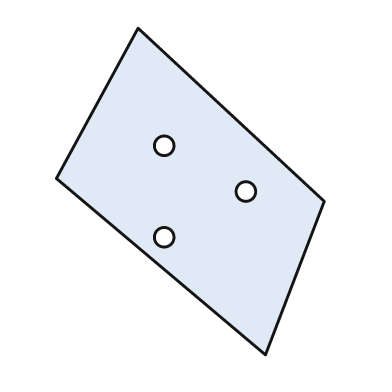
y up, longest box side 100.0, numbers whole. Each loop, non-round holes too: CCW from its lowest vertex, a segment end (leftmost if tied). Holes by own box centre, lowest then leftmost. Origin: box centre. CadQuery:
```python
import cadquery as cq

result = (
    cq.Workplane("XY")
    .moveTo(23.0, -50.0)
    .lineTo(41.0, -3.0)
    .lineTo(-16.0, 50.0)
    .lineTo(-41.0, 4.0)
    .close()
    .moveTo(-8.0, -14.0)
    .circle(3.0)
    .moveTo(17.0, 0.0)
    .circle(3.0)
    .moveTo(-8.0, 14.0)
    .circle(3.0)
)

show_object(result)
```